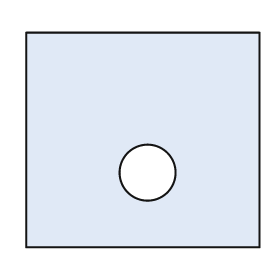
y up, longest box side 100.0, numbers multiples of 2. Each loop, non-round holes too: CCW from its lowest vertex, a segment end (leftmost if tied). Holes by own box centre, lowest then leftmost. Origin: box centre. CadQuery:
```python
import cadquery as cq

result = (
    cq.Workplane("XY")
    .moveTo(-50.0, -46.0)
    .lineTo(50.0, -46.0)
    .lineTo(50.0, 46.0)
    .lineTo(-50.0, 46.0)
    .close()
    .moveTo(2.0, -14.0)
    .circle(12.0)
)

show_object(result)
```